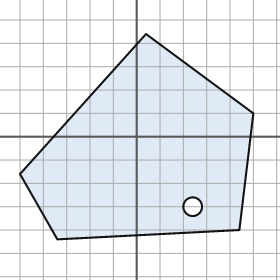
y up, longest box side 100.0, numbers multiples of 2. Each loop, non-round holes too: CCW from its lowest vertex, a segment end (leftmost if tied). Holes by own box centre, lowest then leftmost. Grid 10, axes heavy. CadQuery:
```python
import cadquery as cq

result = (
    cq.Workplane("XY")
    .moveTo(-34.0, -44.0)
    .lineTo(44.0, -40.0)
    .lineTo(50.0, 10.0)
    .lineTo(4.0, 44.0)
    .lineTo(-50.0, -16.0)
    .close()
    .moveTo(24.0, -30.0)
    .circle(4.0)
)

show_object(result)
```